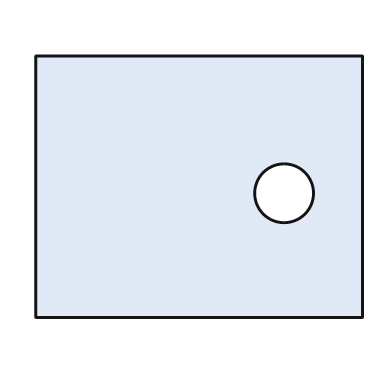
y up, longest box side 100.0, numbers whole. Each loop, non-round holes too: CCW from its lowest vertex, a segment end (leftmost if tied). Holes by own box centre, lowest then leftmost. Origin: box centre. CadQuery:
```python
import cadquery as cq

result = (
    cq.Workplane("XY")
    .moveTo(-50.0, -40.0)
    .lineTo(50.0, -40.0)
    .lineTo(50.0, 40.0)
    .lineTo(-50.0, 40.0)
    .close()
    .moveTo(26.0, -2.0)
    .circle(9.0)
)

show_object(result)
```